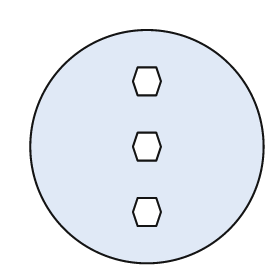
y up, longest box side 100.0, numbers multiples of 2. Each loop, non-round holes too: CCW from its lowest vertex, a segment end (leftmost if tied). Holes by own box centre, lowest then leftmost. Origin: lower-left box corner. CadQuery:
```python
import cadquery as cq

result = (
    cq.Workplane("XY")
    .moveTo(50.0, 50.0)
    .circle(50.0)
    .moveTo(46.0, 16.0)
    .lineTo(54.0, 16.0)
    .lineTo(56.0, 22.0)
    .lineTo(54.0, 28.0)
    .lineTo(46.0, 28.0)
    .lineTo(44.0, 22.0)
    .close()
    .moveTo(46.0, 44.0)
    .lineTo(54.0, 44.0)
    .lineTo(56.0, 50.0)
    .lineTo(54.0, 56.0)
    .lineTo(46.0, 56.0)
    .lineTo(44.0, 50.0)
    .close()
    .moveTo(46.0, 72.0)
    .lineTo(54.0, 72.0)
    .lineTo(56.0, 78.0)
    .lineTo(54.0, 84.0)
    .lineTo(46.0, 84.0)
    .lineTo(44.0, 78.0)
    .close()
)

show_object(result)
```